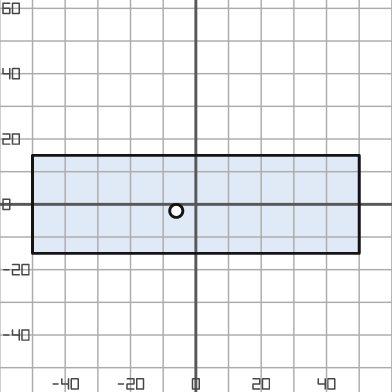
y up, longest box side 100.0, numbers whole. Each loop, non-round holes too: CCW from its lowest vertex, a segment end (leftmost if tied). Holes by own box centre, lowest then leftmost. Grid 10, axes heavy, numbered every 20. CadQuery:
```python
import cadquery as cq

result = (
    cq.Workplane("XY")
    .moveTo(-50.0, -15.0)
    .lineTo(50.0, -15.0)
    .lineTo(50.0, 15.0)
    .lineTo(-50.0, 15.0)
    .close()
    .moveTo(-6.0, -2.0)
    .circle(2.0)
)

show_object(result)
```